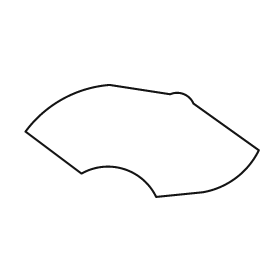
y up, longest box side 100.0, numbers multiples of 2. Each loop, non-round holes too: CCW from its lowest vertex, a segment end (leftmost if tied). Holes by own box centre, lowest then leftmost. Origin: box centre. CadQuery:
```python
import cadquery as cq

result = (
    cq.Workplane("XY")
    .moveTo(6.0, -24.0)
    .lineTo(26.0, -22.0)
    .threePointArc((40.0, -16.0), (50.0, -4.0))
    .lineTo(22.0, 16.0)
    .threePointArc((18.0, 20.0), (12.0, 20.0))
    .lineTo(-14.0, 24.0)
    .threePointArc((-34.0, 18.0), (-50.0, 4.0))
    .lineTo(-26.0, -14.0)
    .threePointArc((-8.0, -12.0), (6.0, -24.0))
    .close()
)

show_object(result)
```